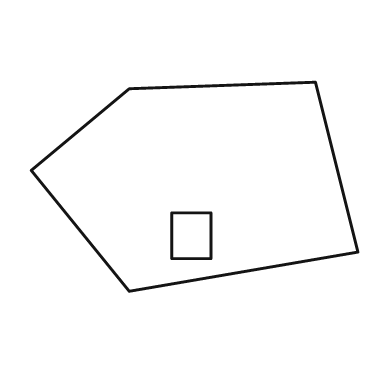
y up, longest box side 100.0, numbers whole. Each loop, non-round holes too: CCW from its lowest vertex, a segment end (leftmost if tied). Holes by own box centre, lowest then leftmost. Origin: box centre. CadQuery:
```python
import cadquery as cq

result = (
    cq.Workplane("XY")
    .moveTo(-20.0, -32.0)
    .lineTo(50.0, -20.0)
    .lineTo(37.0, 32.0)
    .lineTo(-20.0, 30.0)
    .lineTo(-50.0, 5.0)
    .close()
    .moveTo(-7.0, -22.0)
    .lineTo(5.0, -22.0)
    .lineTo(5.0, -8.0)
    .lineTo(-7.0, -8.0)
    .close()
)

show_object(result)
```